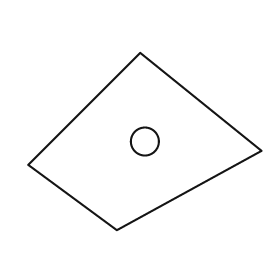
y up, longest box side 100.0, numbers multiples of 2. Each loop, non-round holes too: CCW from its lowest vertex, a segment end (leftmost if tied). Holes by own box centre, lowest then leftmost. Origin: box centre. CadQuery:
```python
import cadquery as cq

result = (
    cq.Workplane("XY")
    .moveTo(-12.0, -38.0)
    .lineTo(50.0, -4.0)
    .lineTo(-2.0, 38.0)
    .lineTo(-50.0, -10.0)
    .close()
    .moveTo(0.0, 0.0)
    .circle(6.0)
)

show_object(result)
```